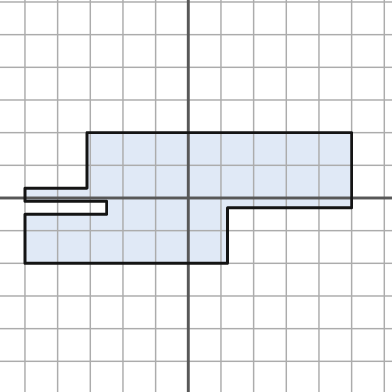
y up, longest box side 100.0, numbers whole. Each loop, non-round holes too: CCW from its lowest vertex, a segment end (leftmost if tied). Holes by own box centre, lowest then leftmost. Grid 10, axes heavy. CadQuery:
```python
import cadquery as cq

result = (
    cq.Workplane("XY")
    .moveTo(-50.0, -20.0)
    .lineTo(12.0, -20.0)
    .lineTo(12.0, -3.0)
    .lineTo(50.0, -3.0)
    .lineTo(50.0, 20.0)
    .lineTo(-31.0, 20.0)
    .lineTo(-31.0, 3.0)
    .lineTo(-50.0, 3.0)
    .lineTo(-50.0, -1.0)
    .lineTo(-25.0, -1.0)
    .lineTo(-25.0, -5.0)
    .lineTo(-50.0, -5.0)
    .close()
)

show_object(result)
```